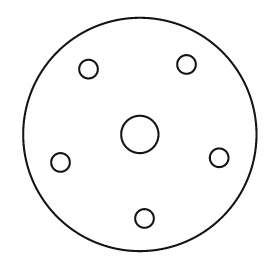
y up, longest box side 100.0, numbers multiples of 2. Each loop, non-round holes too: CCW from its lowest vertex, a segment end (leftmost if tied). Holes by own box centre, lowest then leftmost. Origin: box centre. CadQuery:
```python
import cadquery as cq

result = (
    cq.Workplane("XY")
    .moveTo(0.0, 0.0)
    .circle(50.0)
    .moveTo(2.0, -36.0)
    .circle(4.0)
    .moveTo(-34.0, -12.0)
    .circle(4.0)
    .moveTo(34.0, -10.0)
    .circle(4.0)
    .moveTo(0.0, 0.0)
    .circle(8.0)
    .moveTo(-22.0, 28.0)
    .circle(4.0)
    .moveTo(20.0, 30.0)
    .circle(4.0)
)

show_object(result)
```